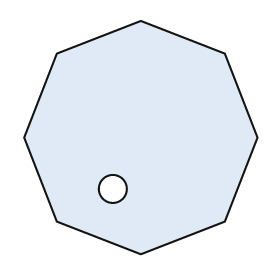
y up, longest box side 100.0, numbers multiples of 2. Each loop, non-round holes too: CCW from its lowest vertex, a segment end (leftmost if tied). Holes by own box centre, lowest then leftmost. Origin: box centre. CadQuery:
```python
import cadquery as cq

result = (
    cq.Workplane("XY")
    .moveTo(0.0, -50.0)
    .lineTo(36.0, -36.0)
    .lineTo(50.0, 0.0)
    .lineTo(36.0, 36.0)
    .lineTo(0.0, 50.0)
    .lineTo(-36.0, 36.0)
    .lineTo(-50.0, 0.0)
    .lineTo(-36.0, -36.0)
    .close()
    .moveTo(-12.0, -22.0)
    .circle(6.0)
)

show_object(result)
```